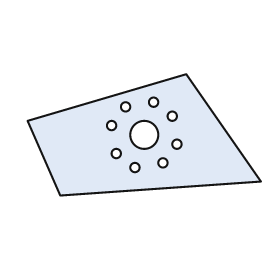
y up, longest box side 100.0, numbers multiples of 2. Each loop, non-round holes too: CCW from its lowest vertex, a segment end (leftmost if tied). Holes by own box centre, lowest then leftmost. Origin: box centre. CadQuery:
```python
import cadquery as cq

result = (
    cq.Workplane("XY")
    .moveTo(-36.0, -26.0)
    .lineTo(50.0, -20.0)
    .lineTo(18.0, 26.0)
    .lineTo(-50.0, 6.0)
    .close()
    .moveTo(-4.0, -14.0)
    .circle(2.0)
    .moveTo(8.0, -12.0)
    .circle(2.0)
    .moveTo(-12.0, -8.0)
    .circle(2.0)
    .moveTo(14.0, -4.0)
    .circle(2.0)
    .moveTo(0.0, 0.0)
    .circle(6.0)
    .moveTo(-14.0, 4.0)
    .circle(2.0)
    .moveTo(12.0, 8.0)
    .circle(2.0)
    .moveTo(-8.0, 12.0)
    .circle(2.0)
    .moveTo(4.0, 14.0)
    .circle(2.0)
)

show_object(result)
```